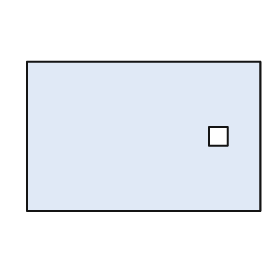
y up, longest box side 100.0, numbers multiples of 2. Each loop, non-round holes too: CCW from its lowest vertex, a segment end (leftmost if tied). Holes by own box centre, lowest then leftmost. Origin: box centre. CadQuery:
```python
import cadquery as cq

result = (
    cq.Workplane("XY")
    .moveTo(-50.0, -32.0)
    .lineTo(50.0, -32.0)
    .lineTo(50.0, 32.0)
    .lineTo(-50.0, 32.0)
    .close()
    .moveTo(28.0, -4.0)
    .lineTo(36.0, -4.0)
    .lineTo(36.0, 4.0)
    .lineTo(28.0, 4.0)
    .close()
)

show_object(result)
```